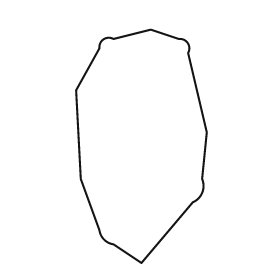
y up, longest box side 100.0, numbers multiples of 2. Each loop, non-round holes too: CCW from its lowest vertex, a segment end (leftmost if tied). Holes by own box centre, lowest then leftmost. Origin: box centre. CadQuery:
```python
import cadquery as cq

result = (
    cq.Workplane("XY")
    .moveTo(0.0, -50.0)
    .lineTo(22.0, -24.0)
    .threePointArc((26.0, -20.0), (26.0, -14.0))
    .lineTo(28.0, 6.0)
    .lineTo(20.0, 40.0)
    .threePointArc((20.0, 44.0), (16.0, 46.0))
    .lineTo(4.0, 50.0)
    .lineTo(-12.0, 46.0)
    .threePointArc((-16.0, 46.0), (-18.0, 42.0))
    .lineTo(-28.0, 24.0)
    .lineTo(-26.0, -14.0)
    .lineTo(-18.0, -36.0)
    .threePointArc((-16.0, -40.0), (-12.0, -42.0))
    .close()
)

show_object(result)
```